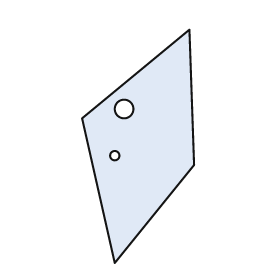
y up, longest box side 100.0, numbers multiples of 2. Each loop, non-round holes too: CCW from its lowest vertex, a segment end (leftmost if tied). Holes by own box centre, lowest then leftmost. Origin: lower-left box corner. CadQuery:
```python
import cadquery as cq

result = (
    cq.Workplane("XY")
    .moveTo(14.0, 0.0)
    .lineTo(48.0, 42.0)
    .lineTo(46.0, 100.0)
    .lineTo(0.0, 62.0)
    .close()
    .moveTo(14.0, 46.0)
    .circle(2.0)
    .moveTo(18.0, 66.0)
    .circle(4.0)
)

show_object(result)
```